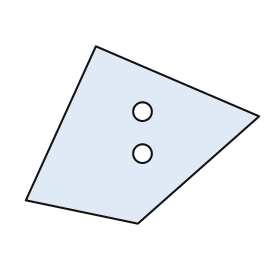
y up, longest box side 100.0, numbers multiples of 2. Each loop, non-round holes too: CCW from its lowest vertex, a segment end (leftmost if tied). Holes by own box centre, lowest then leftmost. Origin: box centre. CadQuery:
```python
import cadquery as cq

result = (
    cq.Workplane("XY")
    .moveTo(-2.0, -38.0)
    .lineTo(50.0, 8.0)
    .lineTo(-20.0, 38.0)
    .lineTo(-50.0, -28.0)
    .close()
    .moveTo(0.0, -8.0)
    .circle(4.0)
    .moveTo(0.0, 10.0)
    .circle(4.0)
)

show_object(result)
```